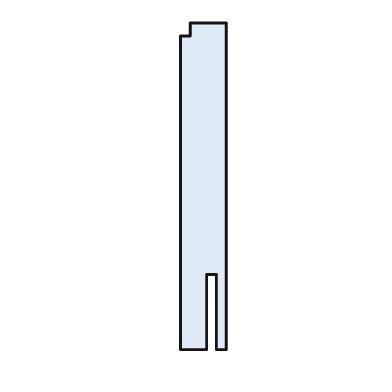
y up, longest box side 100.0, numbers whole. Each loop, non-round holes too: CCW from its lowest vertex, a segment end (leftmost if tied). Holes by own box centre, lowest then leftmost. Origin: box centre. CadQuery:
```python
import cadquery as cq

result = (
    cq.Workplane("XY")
    .moveTo(-7.0, -50.0)
    .lineTo(1.0, -50.0)
    .lineTo(1.0, -27.0)
    .lineTo(4.0, -27.0)
    .lineTo(4.0, -50.0)
    .lineTo(7.0, -50.0)
    .lineTo(7.0, 50.0)
    .lineTo(-4.0, 50.0)
    .lineTo(-4.0, 46.0)
    .lineTo(-7.0, 46.0)
    .close()
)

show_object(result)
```